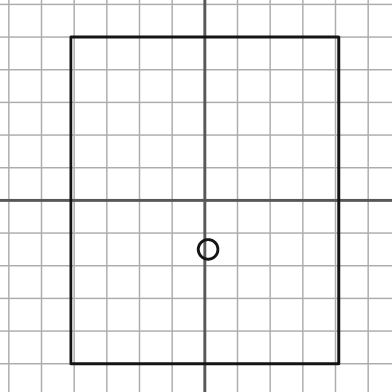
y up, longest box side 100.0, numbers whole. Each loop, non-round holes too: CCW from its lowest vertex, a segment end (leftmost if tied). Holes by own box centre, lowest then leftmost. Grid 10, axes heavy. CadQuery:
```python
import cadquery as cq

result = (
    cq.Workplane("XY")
    .moveTo(-41.0, -50.0)
    .lineTo(41.0, -50.0)
    .lineTo(41.0, 50.0)
    .lineTo(-41.0, 50.0)
    .close()
    .moveTo(1.0, -15.0)
    .circle(3.0)
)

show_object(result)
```